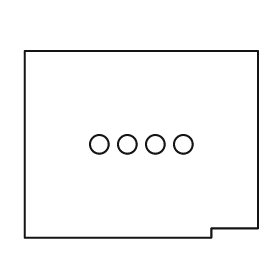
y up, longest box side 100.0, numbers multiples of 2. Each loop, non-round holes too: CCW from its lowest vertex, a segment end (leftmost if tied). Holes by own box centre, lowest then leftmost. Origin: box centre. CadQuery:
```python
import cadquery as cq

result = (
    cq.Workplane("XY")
    .moveTo(-50.0, -40.0)
    .lineTo(30.0, -40.0)
    .lineTo(30.0, -36.0)
    .lineTo(50.0, -36.0)
    .lineTo(50.0, 40.0)
    .lineTo(-50.0, 40.0)
    .close()
    .moveTo(-18.0, 0.0)
    .circle(4.0)
    .moveTo(-6.0, 0.0)
    .circle(4.0)
    .moveTo(6.0, 0.0)
    .circle(4.0)
    .moveTo(18.0, 0.0)
    .circle(4.0)
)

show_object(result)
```